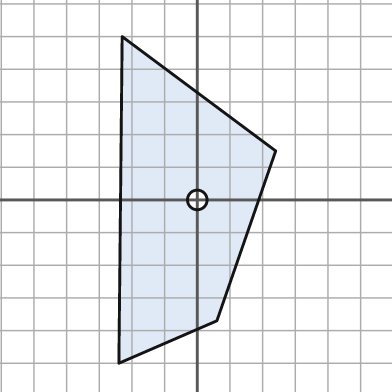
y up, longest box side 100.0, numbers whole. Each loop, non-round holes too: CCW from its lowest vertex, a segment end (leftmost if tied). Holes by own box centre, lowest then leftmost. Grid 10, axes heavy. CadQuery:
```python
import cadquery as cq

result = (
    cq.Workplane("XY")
    .moveTo(-24.0, -50.0)
    .lineTo(6.0, -37.0)
    .lineTo(24.0, 15.0)
    .lineTo(-23.0, 50.0)
    .close()
    .moveTo(0.0, 0.0)
    .circle(3.0)
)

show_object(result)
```